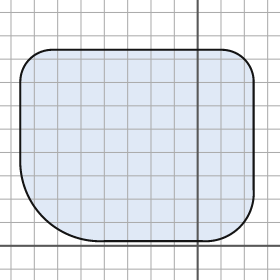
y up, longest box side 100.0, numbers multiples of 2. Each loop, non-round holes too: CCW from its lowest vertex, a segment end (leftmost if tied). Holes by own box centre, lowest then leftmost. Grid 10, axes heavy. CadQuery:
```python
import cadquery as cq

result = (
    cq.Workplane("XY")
    .moveTo(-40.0, 2.0)
    .lineTo(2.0, 2.0)
    .threePointArc((18.0, 8.0), (24.0, 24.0))
    .lineTo(24.0, 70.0)
    .threePointArc((20.0, 80.0), (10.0, 84.0))
    .lineTo(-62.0, 84.0)
    .threePointArc((-72.0, 80.0), (-76.0, 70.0))
    .lineTo(-76.0, 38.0)
    .threePointArc((-66.0, 12.0), (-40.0, 2.0))
    .close()
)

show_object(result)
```